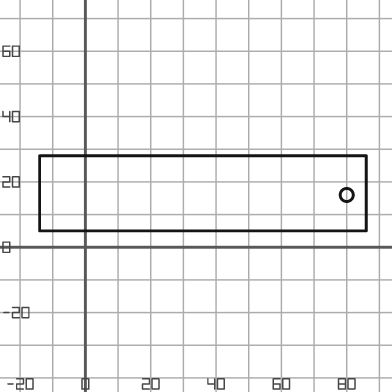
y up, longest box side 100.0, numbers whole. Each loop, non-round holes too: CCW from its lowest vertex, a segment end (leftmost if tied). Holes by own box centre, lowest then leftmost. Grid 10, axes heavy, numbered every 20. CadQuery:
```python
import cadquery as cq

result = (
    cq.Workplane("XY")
    .moveTo(-14.0, 5.0)
    .lineTo(86.0, 5.0)
    .lineTo(86.0, 28.0)
    .lineTo(-14.0, 28.0)
    .close()
    .moveTo(80.0, 16.0)
    .circle(2.0)
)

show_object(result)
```